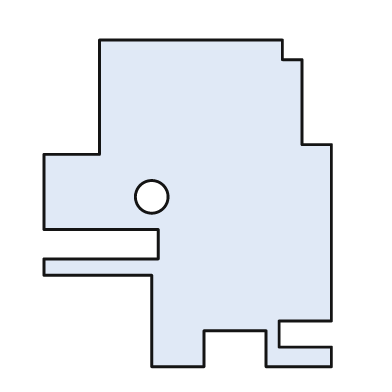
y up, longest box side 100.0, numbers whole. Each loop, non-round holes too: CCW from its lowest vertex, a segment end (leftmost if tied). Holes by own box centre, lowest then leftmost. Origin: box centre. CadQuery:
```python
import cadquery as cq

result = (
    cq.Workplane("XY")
    .moveTo(-11.0, -50.0)
    .lineTo(5.0, -50.0)
    .lineTo(5.0, -39.0)
    .lineTo(24.0, -39.0)
    .lineTo(24.0, -50.0)
    .lineTo(44.0, -50.0)
    .lineTo(44.0, -44.0)
    .lineTo(28.0, -44.0)
    .lineTo(28.0, -36.0)
    .lineTo(44.0, -36.0)
    .lineTo(44.0, 18.0)
    .lineTo(35.0, 18.0)
    .lineTo(35.0, 44.0)
    .lineTo(29.0, 44.0)
    .lineTo(29.0, 50.0)
    .lineTo(-27.0, 50.0)
    .lineTo(-27.0, 15.0)
    .lineTo(-44.0, 15.0)
    .lineTo(-44.0, -8.0)
    .lineTo(-9.0, -8.0)
    .lineTo(-9.0, -17.0)
    .lineTo(-44.0, -17.0)
    .lineTo(-44.0, -22.0)
    .lineTo(-11.0, -22.0)
    .close()
    .moveTo(-11.0, 2.0)
    .circle(5.0)
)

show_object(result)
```